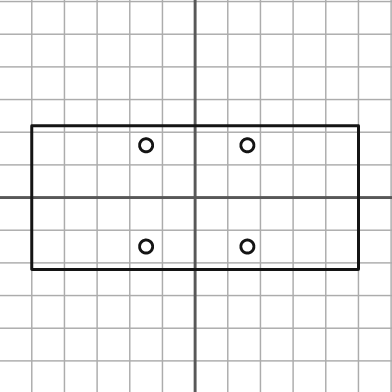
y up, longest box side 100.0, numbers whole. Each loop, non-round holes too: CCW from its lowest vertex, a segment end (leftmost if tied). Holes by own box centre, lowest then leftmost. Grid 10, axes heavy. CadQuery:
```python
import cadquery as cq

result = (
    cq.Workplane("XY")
    .moveTo(-50.0, -22.0)
    .lineTo(50.0, -22.0)
    .lineTo(50.0, 22.0)
    .lineTo(-50.0, 22.0)
    .close()
    .moveTo(-15.0, -15.0)
    .circle(2.0)
    .moveTo(16.0, -15.0)
    .circle(2.0)
    .moveTo(-15.0, 16.0)
    .circle(2.0)
    .moveTo(16.0, 16.0)
    .circle(2.0)
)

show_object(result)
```